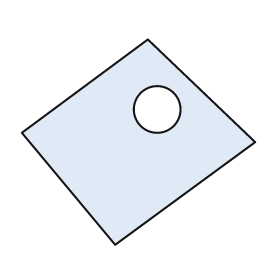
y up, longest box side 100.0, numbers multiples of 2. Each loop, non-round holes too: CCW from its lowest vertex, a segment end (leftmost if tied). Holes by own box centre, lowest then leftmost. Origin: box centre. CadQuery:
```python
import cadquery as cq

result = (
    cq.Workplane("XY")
    .moveTo(-10.0, -44.0)
    .lineTo(50.0, 0.0)
    .lineTo(4.0, 44.0)
    .lineTo(-50.0, 4.0)
    .close()
    .moveTo(8.0, 14.0)
    .circle(10.0)
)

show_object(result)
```